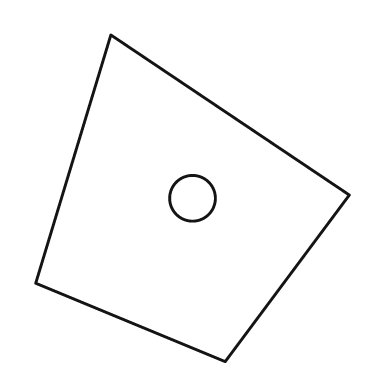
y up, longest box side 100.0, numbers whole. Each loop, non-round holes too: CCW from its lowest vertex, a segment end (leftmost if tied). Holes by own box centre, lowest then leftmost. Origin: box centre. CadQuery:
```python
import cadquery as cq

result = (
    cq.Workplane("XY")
    .moveTo(10.0, -50.0)
    .lineTo(48.0, 1.0)
    .lineTo(-25.0, 50.0)
    .lineTo(-48.0, -26.0)
    .close()
    .moveTo(0.0, 0.0)
    .circle(7.0)
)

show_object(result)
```